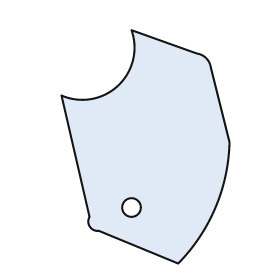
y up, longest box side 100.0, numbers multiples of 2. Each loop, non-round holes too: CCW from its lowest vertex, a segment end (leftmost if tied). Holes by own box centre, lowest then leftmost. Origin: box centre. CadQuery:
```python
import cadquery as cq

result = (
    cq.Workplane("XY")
    .moveTo(14.0, -50.0)
    .threePointArc((30.0, -26.0), (36.0, 2.0))
    .lineTo(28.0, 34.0)
    .threePointArc((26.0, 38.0), (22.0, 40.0))
    .lineTo(-6.0, 50.0)
    .threePointArc((-12.0, 26.0), (-36.0, 22.0))
    .lineTo(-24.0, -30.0)
    .threePointArc((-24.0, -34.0), (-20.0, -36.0))
    .close()
    .moveTo(-6.0, -26.0)
    .circle(4.0)
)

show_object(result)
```